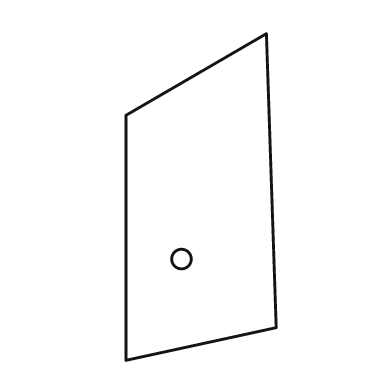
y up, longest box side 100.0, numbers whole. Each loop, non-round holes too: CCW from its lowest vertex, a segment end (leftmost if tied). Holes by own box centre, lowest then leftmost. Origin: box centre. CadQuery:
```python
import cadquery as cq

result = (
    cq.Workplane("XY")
    .moveTo(-23.0, -50.0)
    .lineTo(23.0, -40.0)
    .lineTo(20.0, 50.0)
    .lineTo(-23.0, 25.0)
    .close()
    .moveTo(-6.0, -19.0)
    .circle(3.0)
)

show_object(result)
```